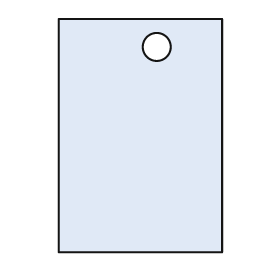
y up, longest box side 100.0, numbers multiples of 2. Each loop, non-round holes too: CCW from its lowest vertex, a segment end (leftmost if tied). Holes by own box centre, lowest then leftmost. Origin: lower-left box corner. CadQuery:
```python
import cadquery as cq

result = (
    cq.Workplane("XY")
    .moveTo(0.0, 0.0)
    .lineTo(70.0, 0.0)
    .lineTo(70.0, 100.0)
    .lineTo(0.0, 100.0)
    .close()
    .moveTo(42.0, 88.0)
    .circle(6.0)
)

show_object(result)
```